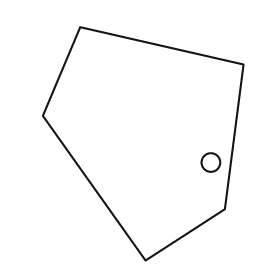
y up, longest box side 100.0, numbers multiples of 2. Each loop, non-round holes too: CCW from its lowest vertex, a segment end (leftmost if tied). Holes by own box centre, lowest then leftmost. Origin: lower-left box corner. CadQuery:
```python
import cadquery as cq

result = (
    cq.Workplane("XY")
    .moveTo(44.0, 0.0)
    .lineTo(78.0, 22.0)
    .lineTo(86.0, 84.0)
    .lineTo(16.0, 100.0)
    .lineTo(0.0, 62.0)
    .close()
    .moveTo(72.0, 42.0)
    .circle(4.0)
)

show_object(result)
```